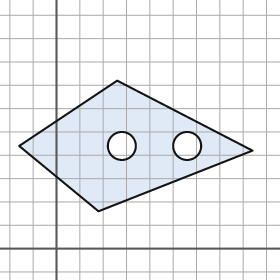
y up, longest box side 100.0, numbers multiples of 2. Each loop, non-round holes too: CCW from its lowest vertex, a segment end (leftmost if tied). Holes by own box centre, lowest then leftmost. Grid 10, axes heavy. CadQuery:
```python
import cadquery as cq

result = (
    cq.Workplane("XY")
    .moveTo(18.0, 16.0)
    .lineTo(84.0, 42.0)
    .lineTo(26.0, 72.0)
    .lineTo(-16.0, 44.0)
    .close()
    .moveTo(28.0, 44.0)
    .circle(6.0)
    .moveTo(56.0, 44.0)
    .circle(6.0)
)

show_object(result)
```